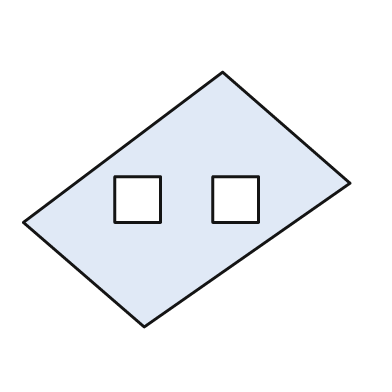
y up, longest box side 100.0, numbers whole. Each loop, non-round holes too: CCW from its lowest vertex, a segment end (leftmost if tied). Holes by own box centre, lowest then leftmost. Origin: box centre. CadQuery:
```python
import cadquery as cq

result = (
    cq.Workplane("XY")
    .moveTo(-13.0, -39.0)
    .lineTo(50.0, 5.0)
    .lineTo(11.0, 39.0)
    .lineTo(-50.0, -7.0)
    .close()
    .moveTo(-22.0, -7.0)
    .lineTo(-8.0, -7.0)
    .lineTo(-8.0, 7.0)
    .lineTo(-22.0, 7.0)
    .close()
    .moveTo(8.0, -7.0)
    .lineTo(22.0, -7.0)
    .lineTo(22.0, 7.0)
    .lineTo(8.0, 7.0)
    .close()
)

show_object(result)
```